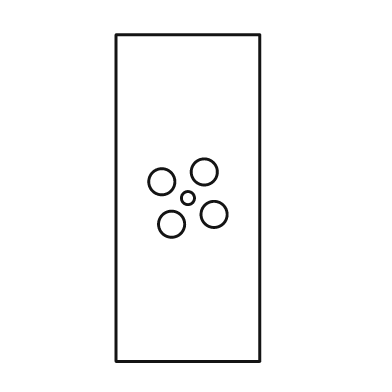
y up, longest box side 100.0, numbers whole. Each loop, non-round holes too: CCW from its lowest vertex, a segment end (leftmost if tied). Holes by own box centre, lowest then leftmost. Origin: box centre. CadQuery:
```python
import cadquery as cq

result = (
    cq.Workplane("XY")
    .moveTo(-22.0, -50.0)
    .lineTo(22.0, -50.0)
    .lineTo(22.0, 50.0)
    .lineTo(-22.0, 50.0)
    .close()
    .moveTo(-5.0, -8.0)
    .circle(4.0)
    .moveTo(8.0, -5.0)
    .circle(4.0)
    .moveTo(0.0, 0.0)
    .circle(2.0)
    .moveTo(-8.0, 5.0)
    .circle(4.0)
    .moveTo(5.0, 8.0)
    .circle(4.0)
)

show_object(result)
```